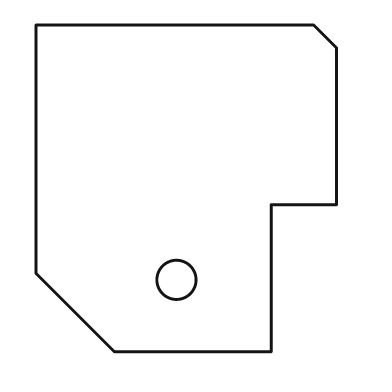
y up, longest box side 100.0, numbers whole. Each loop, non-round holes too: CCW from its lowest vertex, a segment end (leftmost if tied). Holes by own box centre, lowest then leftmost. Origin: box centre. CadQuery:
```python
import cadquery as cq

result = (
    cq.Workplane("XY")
    .moveTo(-22.0, -50.0)
    .lineTo(26.0, -50.0)
    .lineTo(26.0, -5.0)
    .lineTo(46.0, -5.0)
    .lineTo(46.0, 43.0)
    .lineTo(39.0, 50.0)
    .lineTo(-46.0, 50.0)
    .lineTo(-46.0, -26.0)
    .close()
    .moveTo(-3.0, -28.0)
    .circle(6.0)
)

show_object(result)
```